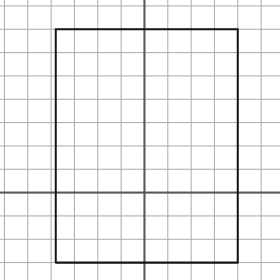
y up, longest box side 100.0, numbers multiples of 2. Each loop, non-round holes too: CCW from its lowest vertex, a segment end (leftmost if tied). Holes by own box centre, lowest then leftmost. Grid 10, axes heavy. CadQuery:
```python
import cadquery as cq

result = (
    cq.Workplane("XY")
    .moveTo(-38.0, -30.0)
    .lineTo(40.0, -30.0)
    .lineTo(40.0, 70.0)
    .lineTo(-38.0, 70.0)
    .close()
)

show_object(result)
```